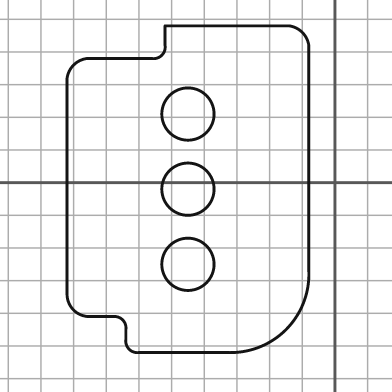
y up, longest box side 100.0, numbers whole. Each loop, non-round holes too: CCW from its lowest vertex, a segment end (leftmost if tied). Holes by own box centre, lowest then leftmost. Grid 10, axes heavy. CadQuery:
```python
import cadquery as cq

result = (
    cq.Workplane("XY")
    .moveTo(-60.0, -52.0)
    .lineTo(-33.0, -52.0)
    .threePointArc((-15.0, -45.0), (-8.0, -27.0))
    .lineTo(-8.0, 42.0)
    .threePointArc((-10.0, 46.0), (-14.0, 48.0))
    .lineTo(-52.0, 48.0)
    .lineTo(-52.0, 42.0)
    .threePointArc((-53.0, 39.0), (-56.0, 38.0))
    .lineTo(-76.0, 38.0)
    .threePointArc((-80.0, 36.0), (-82.0, 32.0))
    .lineTo(-82.0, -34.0)
    .threePointArc((-80.0, -39.0), (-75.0, -41.0))
    .lineTo(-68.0, -41.0)
    .threePointArc((-65.0, -42.0), (-64.0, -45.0))
    .lineTo(-64.0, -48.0)
    .threePointArc((-63.0, -51.0), (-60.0, -52.0))
    .close()
    .moveTo(-45.0, -25.0)
    .circle(8.0)
    .moveTo(-45.0, -2.0)
    .circle(8.0)
    .moveTo(-45.0, 21.0)
    .circle(8.0)
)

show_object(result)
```